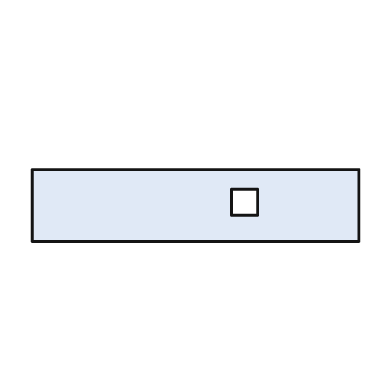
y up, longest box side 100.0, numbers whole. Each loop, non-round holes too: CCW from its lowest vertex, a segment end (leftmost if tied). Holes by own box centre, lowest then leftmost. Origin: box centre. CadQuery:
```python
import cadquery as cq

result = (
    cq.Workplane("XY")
    .moveTo(-50.0, -11.0)
    .lineTo(50.0, -11.0)
    .lineTo(50.0, 11.0)
    .lineTo(-50.0, 11.0)
    .close()
    .moveTo(11.0, -3.0)
    .lineTo(19.0, -3.0)
    .lineTo(19.0, 5.0)
    .lineTo(11.0, 5.0)
    .close()
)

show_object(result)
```